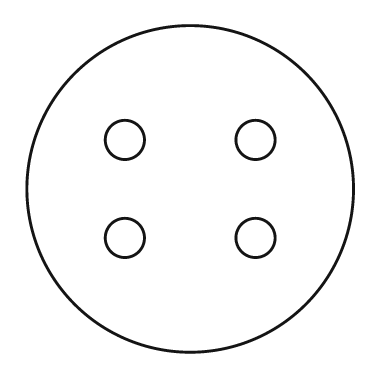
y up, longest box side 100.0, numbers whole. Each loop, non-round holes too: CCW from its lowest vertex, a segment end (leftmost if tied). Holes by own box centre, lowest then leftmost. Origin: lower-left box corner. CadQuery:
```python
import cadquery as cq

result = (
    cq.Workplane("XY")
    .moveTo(50.0, 50.0)
    .circle(50.0)
    .moveTo(30.0, 35.0)
    .circle(6.0)
    .moveTo(70.0, 35.0)
    .circle(6.0)
    .moveTo(30.0, 65.0)
    .circle(6.0)
    .moveTo(70.0, 65.0)
    .circle(6.0)
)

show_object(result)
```